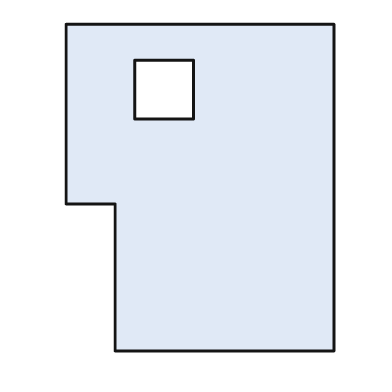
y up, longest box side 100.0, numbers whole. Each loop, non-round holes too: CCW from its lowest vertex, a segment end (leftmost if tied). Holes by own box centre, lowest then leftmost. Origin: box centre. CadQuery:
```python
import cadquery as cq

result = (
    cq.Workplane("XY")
    .moveTo(-26.0, -50.0)
    .lineTo(41.0, -50.0)
    .lineTo(41.0, 50.0)
    .lineTo(-41.0, 50.0)
    .lineTo(-41.0, -5.0)
    .lineTo(-26.0, -5.0)
    .close()
    .moveTo(-20.0, 21.0)
    .lineTo(-2.0, 21.0)
    .lineTo(-2.0, 39.0)
    .lineTo(-20.0, 39.0)
    .close()
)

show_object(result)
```